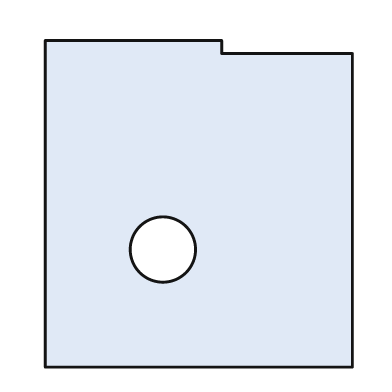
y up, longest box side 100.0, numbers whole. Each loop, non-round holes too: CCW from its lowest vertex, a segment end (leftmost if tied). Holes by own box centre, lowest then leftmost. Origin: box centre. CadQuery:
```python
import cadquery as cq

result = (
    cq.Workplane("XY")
    .moveTo(-47.0, -50.0)
    .lineTo(47.0, -50.0)
    .lineTo(47.0, 46.0)
    .lineTo(7.0, 46.0)
    .lineTo(7.0, 50.0)
    .lineTo(-47.0, 50.0)
    .close()
    .moveTo(-11.0, -14.0)
    .circle(10.0)
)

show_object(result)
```